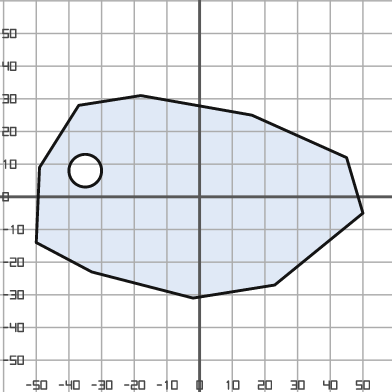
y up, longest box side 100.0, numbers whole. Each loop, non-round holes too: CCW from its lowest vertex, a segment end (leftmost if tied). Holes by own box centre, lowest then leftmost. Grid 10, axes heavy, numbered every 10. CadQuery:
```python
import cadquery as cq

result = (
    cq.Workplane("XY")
    .moveTo(-2.0, -31.0)
    .lineTo(23.0, -27.0)
    .lineTo(50.0, -5.0)
    .lineTo(45.0, 12.0)
    .lineTo(16.0, 25.0)
    .lineTo(-18.0, 31.0)
    .lineTo(-37.0, 28.0)
    .lineTo(-49.0, 9.0)
    .lineTo(-50.0, -14.0)
    .lineTo(-33.0, -23.0)
    .close()
    .moveTo(-35.0, 8.0)
    .circle(5.0)
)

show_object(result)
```